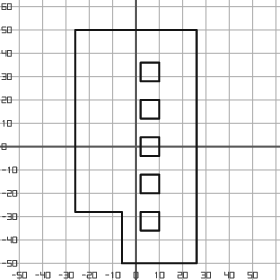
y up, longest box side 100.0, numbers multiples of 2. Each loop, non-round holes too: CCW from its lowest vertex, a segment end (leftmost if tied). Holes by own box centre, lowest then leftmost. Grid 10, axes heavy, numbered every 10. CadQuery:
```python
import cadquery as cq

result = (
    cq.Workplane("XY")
    .moveTo(-6.0, -50.0)
    .lineTo(26.0, -50.0)
    .lineTo(26.0, 50.0)
    .lineTo(-26.0, 50.0)
    .lineTo(-26.0, -28.0)
    .lineTo(-6.0, -28.0)
    .close()
    .moveTo(2.0, -36.0)
    .lineTo(10.0, -36.0)
    .lineTo(10.0, -28.0)
    .lineTo(2.0, -28.0)
    .close()
    .moveTo(2.0, -20.0)
    .lineTo(10.0, -20.0)
    .lineTo(10.0, -12.0)
    .lineTo(2.0, -12.0)
    .close()
    .moveTo(2.0, -4.0)
    .lineTo(10.0, -4.0)
    .lineTo(10.0, 4.0)
    .lineTo(2.0, 4.0)
    .close()
    .moveTo(2.0, 12.0)
    .lineTo(10.0, 12.0)
    .lineTo(10.0, 20.0)
    .lineTo(2.0, 20.0)
    .close()
    .moveTo(2.0, 28.0)
    .lineTo(10.0, 28.0)
    .lineTo(10.0, 36.0)
    .lineTo(2.0, 36.0)
    .close()
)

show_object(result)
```